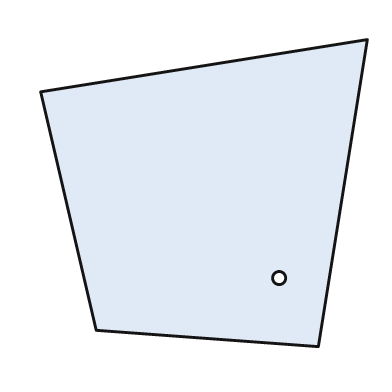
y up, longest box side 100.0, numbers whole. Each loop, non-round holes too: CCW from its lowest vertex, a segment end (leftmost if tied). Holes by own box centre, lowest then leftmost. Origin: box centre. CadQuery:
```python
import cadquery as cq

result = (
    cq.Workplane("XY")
    .moveTo(35.0, -47.0)
    .lineTo(50.0, 47.0)
    .lineTo(-50.0, 31.0)
    .lineTo(-33.0, -42.0)
    .close()
    .moveTo(23.0, -26.0)
    .circle(2.0)
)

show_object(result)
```